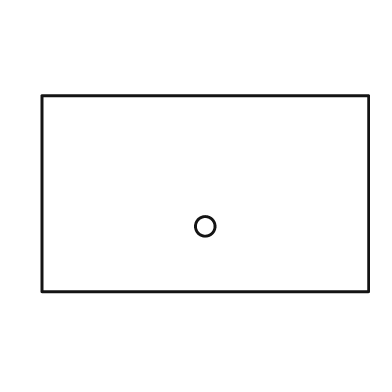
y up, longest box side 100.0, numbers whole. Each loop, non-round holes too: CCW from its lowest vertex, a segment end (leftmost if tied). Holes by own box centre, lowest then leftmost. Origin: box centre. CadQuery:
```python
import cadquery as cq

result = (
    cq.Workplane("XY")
    .moveTo(-50.0, -30.0)
    .lineTo(50.0, -30.0)
    .lineTo(50.0, 30.0)
    .lineTo(-50.0, 30.0)
    .close()
    .moveTo(0.0, -10.0)
    .circle(3.0)
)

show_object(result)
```